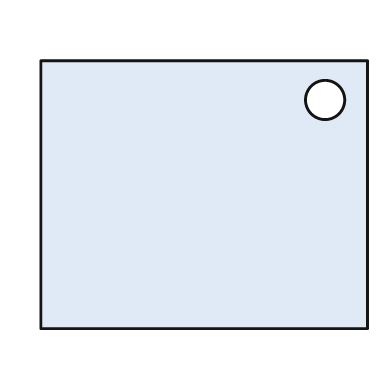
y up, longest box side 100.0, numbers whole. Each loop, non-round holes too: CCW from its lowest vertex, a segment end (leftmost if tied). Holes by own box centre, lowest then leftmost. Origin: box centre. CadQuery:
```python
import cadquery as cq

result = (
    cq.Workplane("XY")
    .moveTo(-50.0, -41.0)
    .lineTo(50.0, -41.0)
    .lineTo(50.0, 41.0)
    .lineTo(-50.0, 41.0)
    .close()
    .moveTo(37.0, 29.0)
    .circle(6.0)
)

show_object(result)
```